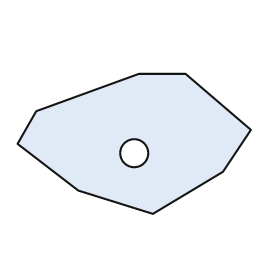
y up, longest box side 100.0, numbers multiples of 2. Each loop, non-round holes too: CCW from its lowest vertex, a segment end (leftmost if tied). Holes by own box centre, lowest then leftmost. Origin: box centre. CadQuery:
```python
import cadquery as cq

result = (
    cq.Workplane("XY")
    .moveTo(8.0, -30.0)
    .lineTo(38.0, -12.0)
    .lineTo(50.0, 6.0)
    .lineTo(22.0, 30.0)
    .lineTo(2.0, 30.0)
    .lineTo(-42.0, 14.0)
    .lineTo(-50.0, 0.0)
    .lineTo(-24.0, -20.0)
    .close()
    .moveTo(0.0, -4.0)
    .circle(6.0)
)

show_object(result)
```